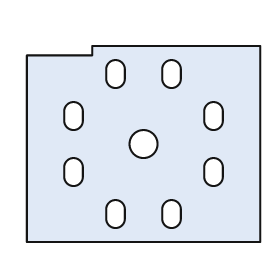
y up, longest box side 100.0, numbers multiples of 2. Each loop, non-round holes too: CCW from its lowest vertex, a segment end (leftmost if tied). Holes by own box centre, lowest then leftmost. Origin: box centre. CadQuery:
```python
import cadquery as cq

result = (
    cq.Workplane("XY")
    .moveTo(-50.0, -42.0)
    .lineTo(50.0, -42.0)
    .lineTo(50.0, 42.0)
    .lineTo(-22.0, 42.0)
    .lineTo(-22.0, 38.0)
    .lineTo(-50.0, 38.0)
    .close()
    .moveTo(-16.0, -32.0)
    .threePointArc((-12.0, -36.0), (-8.0, -32.0))
    .lineTo(-8.0, -28.0)
    .threePointArc((-12.0, -24.0), (-16.0, -28.0))
    .close()
    .moveTo(8.0, -32.0)
    .threePointArc((12.0, -36.0), (16.0, -32.0))
    .lineTo(16.0, -28.0)
    .threePointArc((12.0, -24.0), (8.0, -28.0))
    .close()
    .moveTo(-34.0, -14.0)
    .threePointArc((-30.0, -18.0), (-26.0, -14.0))
    .lineTo(-26.0, -10.0)
    .threePointArc((-30.0, -6.0), (-34.0, -10.0))
    .close()
    .moveTo(26.0, -14.0)
    .threePointArc((30.0, -18.0), (34.0, -14.0))
    .lineTo(34.0, -10.0)
    .threePointArc((30.0, -6.0), (26.0, -10.0))
    .close()
    .moveTo(0.0, 0.0)
    .circle(6.0)
    .moveTo(-34.0, 10.0)
    .threePointArc((-30.0, 6.0), (-26.0, 10.0))
    .lineTo(-26.0, 14.0)
    .threePointArc((-30.0, 18.0), (-34.0, 14.0))
    .close()
    .moveTo(26.0, 10.0)
    .threePointArc((30.0, 6.0), (34.0, 10.0))
    .lineTo(34.0, 14.0)
    .threePointArc((30.0, 18.0), (26.0, 14.0))
    .close()
    .moveTo(-16.0, 28.0)
    .threePointArc((-12.0, 24.0), (-8.0, 28.0))
    .lineTo(-8.0, 32.0)
    .threePointArc((-12.0, 36.0), (-16.0, 32.0))
    .close()
    .moveTo(8.0, 28.0)
    .threePointArc((12.0, 24.0), (16.0, 28.0))
    .lineTo(16.0, 32.0)
    .threePointArc((12.0, 36.0), (8.0, 32.0))
    .close()
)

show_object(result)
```